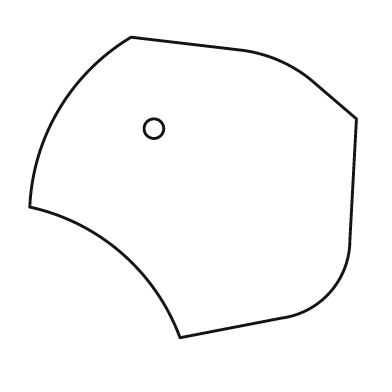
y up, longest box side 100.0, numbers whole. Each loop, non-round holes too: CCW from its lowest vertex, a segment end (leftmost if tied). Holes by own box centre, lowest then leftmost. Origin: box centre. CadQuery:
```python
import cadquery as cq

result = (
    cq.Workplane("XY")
    .moveTo(-4.0, -46.0)
    .lineTo(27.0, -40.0)
    .threePointArc((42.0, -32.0), (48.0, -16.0))
    .lineTo(50.0, 21.0)
    .lineTo(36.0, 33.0)
    .threePointArc((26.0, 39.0), (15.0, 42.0))
    .lineTo(-19.0, 46.0)
    .threePointArc((-41.0, 24.0), (-50.0, -6.0))
    .threePointArc((-22.0, -20.0), (-4.0, -46.0))
    .close()
    .moveTo(-12.0, 18.0)
    .circle(3.0)
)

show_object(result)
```